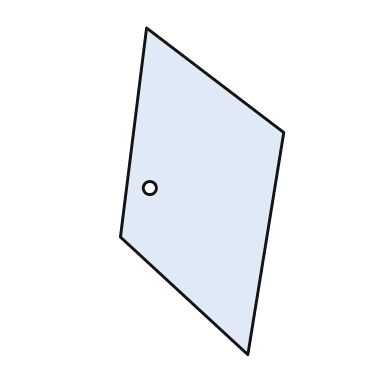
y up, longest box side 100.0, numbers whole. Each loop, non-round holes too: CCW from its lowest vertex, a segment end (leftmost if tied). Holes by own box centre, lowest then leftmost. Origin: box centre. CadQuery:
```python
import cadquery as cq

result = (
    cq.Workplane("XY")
    .moveTo(14.0, -50.0)
    .lineTo(25.0, 18.0)
    .lineTo(-17.0, 50.0)
    .lineTo(-25.0, -14.0)
    .close()
    .moveTo(-16.0, 1.0)
    .circle(2.0)
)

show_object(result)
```